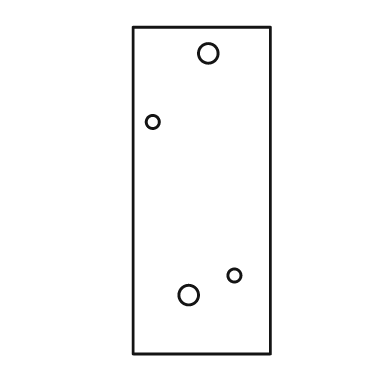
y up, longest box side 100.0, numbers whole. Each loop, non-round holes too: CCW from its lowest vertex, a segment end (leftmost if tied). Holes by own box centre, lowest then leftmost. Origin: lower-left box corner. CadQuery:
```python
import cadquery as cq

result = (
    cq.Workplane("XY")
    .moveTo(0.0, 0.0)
    .lineTo(42.0, 0.0)
    .lineTo(42.0, 100.0)
    .lineTo(0.0, 100.0)
    .close()
    .moveTo(17.0, 18.0)
    .circle(3.0)
    .moveTo(31.0, 24.0)
    .circle(2.0)
    .moveTo(6.0, 71.0)
    .circle(2.0)
    .moveTo(23.0, 92.0)
    .circle(3.0)
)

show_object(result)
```